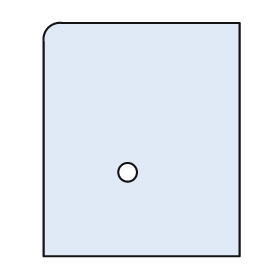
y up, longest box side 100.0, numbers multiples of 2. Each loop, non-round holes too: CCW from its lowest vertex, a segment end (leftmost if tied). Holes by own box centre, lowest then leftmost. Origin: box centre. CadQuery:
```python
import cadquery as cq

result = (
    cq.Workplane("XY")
    .moveTo(-42.0, -50.0)
    .lineTo(42.0, -50.0)
    .lineTo(42.0, 50.0)
    .lineTo(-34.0, 50.0)
    .threePointArc((-40.0, 48.0), (-42.0, 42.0))
    .close()
    .moveTo(-6.0, -14.0)
    .circle(4.0)
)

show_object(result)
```